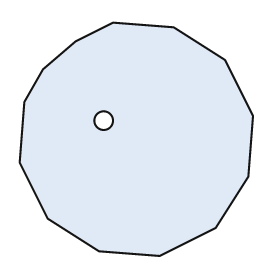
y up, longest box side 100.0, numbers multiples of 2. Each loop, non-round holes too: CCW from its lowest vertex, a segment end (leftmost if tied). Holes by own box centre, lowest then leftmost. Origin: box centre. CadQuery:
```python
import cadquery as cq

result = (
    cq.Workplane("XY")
    .moveTo(10.0, -50.0)
    .lineTo(34.0, -38.0)
    .lineTo(48.0, -16.0)
    .lineTo(50.0, 10.0)
    .lineTo(38.0, 34.0)
    .lineTo(16.0, 48.0)
    .lineTo(-10.0, 50.0)
    .lineTo(-26.0, 42.0)
    .lineTo(-40.0, 30.0)
    .lineTo(-48.0, 16.0)
    .lineTo(-50.0, -10.0)
    .lineTo(-38.0, -34.0)
    .lineTo(-16.0, -48.0)
    .close()
    .moveTo(-14.0, 8.0)
    .circle(4.0)
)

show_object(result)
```